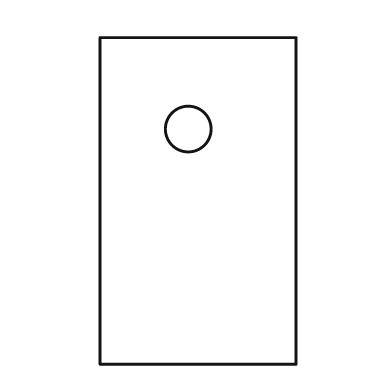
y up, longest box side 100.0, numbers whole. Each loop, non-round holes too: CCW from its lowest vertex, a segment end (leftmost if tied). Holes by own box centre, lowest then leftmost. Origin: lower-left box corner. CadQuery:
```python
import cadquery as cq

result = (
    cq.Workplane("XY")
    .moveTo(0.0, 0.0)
    .lineTo(60.0, 0.0)
    .lineTo(60.0, 100.0)
    .lineTo(0.0, 100.0)
    .close()
    .moveTo(27.0, 72.0)
    .circle(7.0)
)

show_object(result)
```